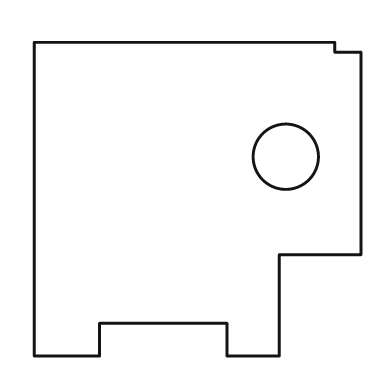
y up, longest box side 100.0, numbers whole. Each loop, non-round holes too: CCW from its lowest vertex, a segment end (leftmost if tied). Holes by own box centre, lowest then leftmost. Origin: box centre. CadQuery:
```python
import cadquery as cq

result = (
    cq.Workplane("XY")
    .moveTo(-50.0, -48.0)
    .lineTo(-30.0, -48.0)
    .lineTo(-30.0, -38.0)
    .lineTo(9.0, -38.0)
    .lineTo(9.0, -48.0)
    .lineTo(25.0, -48.0)
    .lineTo(25.0, -17.0)
    .lineTo(50.0, -17.0)
    .lineTo(50.0, 45.0)
    .lineTo(42.0, 45.0)
    .lineTo(42.0, 48.0)
    .lineTo(-50.0, 48.0)
    .close()
    .moveTo(27.0, 13.0)
    .circle(10.0)
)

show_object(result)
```